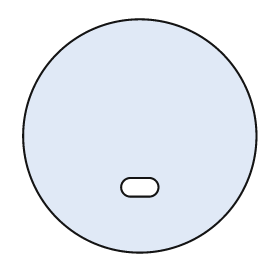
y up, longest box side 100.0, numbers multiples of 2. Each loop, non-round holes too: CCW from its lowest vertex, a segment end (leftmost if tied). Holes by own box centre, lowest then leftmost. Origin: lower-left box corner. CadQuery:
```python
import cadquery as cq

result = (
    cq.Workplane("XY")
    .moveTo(50.0, 50.0)
    .circle(50.0)
    .moveTo(46.0, 24.0)
    .lineTo(54.0, 24.0)
    .threePointArc((58.0, 28.0), (54.0, 32.0))
    .lineTo(46.0, 32.0)
    .threePointArc((42.0, 28.0), (46.0, 24.0))
    .close()
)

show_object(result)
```